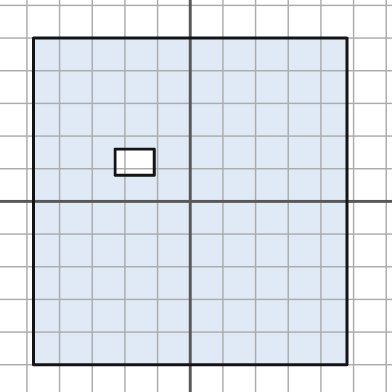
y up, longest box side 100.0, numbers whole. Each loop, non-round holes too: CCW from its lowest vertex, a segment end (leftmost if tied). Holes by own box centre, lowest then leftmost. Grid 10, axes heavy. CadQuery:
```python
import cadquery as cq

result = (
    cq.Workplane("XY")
    .moveTo(-48.0, -50.0)
    .lineTo(48.0, -50.0)
    .lineTo(48.0, 50.0)
    .lineTo(-48.0, 50.0)
    .close()
    .moveTo(-23.0, 8.0)
    .lineTo(-11.0, 8.0)
    .lineTo(-11.0, 16.0)
    .lineTo(-23.0, 16.0)
    .close()
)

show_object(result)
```